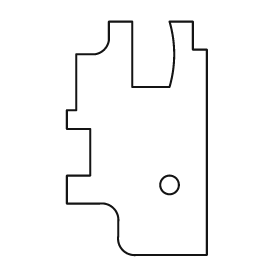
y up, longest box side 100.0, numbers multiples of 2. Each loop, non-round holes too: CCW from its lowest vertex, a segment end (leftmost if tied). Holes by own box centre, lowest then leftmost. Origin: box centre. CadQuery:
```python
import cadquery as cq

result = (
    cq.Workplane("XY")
    .moveTo(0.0, -50.0)
    .lineTo(30.0, -50.0)
    .lineTo(30.0, 38.0)
    .lineTo(24.0, 38.0)
    .lineTo(24.0, 50.0)
    .lineTo(14.0, 50.0)
    .threePointArc((16.0, 36.0), (14.0, 22.0))
    .lineTo(-2.0, 22.0)
    .lineTo(-2.0, 50.0)
    .lineTo(-12.0, 50.0)
    .lineTo(-12.0, 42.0)
    .threePointArc((-14.0, 38.0), (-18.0, 36.0))
    .lineTo(-26.0, 36.0)
    .lineTo(-26.0, 12.0)
    .lineTo(-30.0, 12.0)
    .lineTo(-30.0, 4.0)
    .lineTo(-20.0, 4.0)
    .lineTo(-20.0, -16.0)
    .lineTo(-30.0, -16.0)
    .lineTo(-30.0, -28.0)
    .lineTo(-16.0, -28.0)
    .threePointArc((-10.0, -30.0), (-8.0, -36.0))
    .lineTo(-8.0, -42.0)
    .threePointArc((-6.0, -48.0), (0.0, -50.0))
    .close()
    .moveTo(14.0, -20.0)
    .circle(4.0)
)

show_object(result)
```